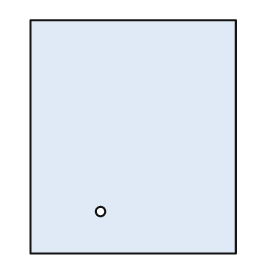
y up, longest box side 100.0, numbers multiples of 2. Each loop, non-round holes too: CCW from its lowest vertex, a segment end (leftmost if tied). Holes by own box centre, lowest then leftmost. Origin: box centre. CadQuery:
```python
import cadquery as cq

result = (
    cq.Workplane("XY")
    .moveTo(-44.0, -50.0)
    .lineTo(44.0, -50.0)
    .lineTo(44.0, 50.0)
    .lineTo(-44.0, 50.0)
    .close()
    .moveTo(-14.0, -32.0)
    .circle(2.0)
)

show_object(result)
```